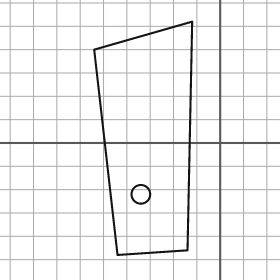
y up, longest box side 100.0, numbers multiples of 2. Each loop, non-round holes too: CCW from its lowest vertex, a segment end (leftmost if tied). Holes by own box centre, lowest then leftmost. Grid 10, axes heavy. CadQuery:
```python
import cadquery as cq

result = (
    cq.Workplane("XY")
    .moveTo(-44.0, -48.0)
    .lineTo(-14.0, -46.0)
    .lineTo(-12.0, 52.0)
    .lineTo(-54.0, 40.0)
    .close()
    .moveTo(-34.0, -22.0)
    .circle(4.0)
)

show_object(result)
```